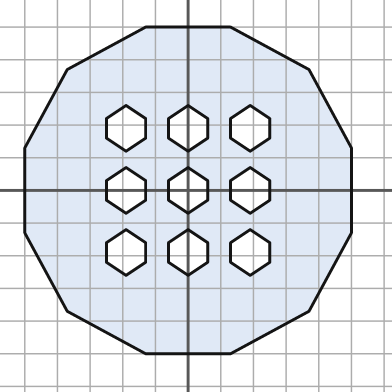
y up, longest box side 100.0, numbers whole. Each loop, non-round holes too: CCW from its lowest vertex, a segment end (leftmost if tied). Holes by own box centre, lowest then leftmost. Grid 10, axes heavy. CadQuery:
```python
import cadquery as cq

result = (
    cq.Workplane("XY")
    .moveTo(-13.0, -50.0)
    .lineTo(13.0, -50.0)
    .lineTo(37.0, -37.0)
    .lineTo(50.0, -13.0)
    .lineTo(50.0, 13.0)
    .lineTo(37.0, 37.0)
    .lineTo(13.0, 50.0)
    .lineTo(-13.0, 50.0)
    .lineTo(-37.0, 37.0)
    .lineTo(-50.0, 13.0)
    .lineTo(-50.0, -13.0)
    .lineTo(-37.0, -37.0)
    .close()
    .moveTo(-19.0, -26.0)
    .lineTo(-13.0, -22.0)
    .lineTo(-13.0, -16.0)
    .lineTo(-19.0, -12.0)
    .lineTo(-25.0, -16.0)
    .lineTo(-25.0, -22.0)
    .close()
    .moveTo(0.0, -26.0)
    .lineTo(6.0, -22.0)
    .lineTo(6.0, -16.0)
    .lineTo(0.0, -12.0)
    .lineTo(-6.0, -16.0)
    .lineTo(-6.0, -22.0)
    .close()
    .moveTo(19.0, -26.0)
    .lineTo(25.0, -22.0)
    .lineTo(25.0, -16.0)
    .lineTo(19.0, -12.0)
    .lineTo(13.0, -16.0)
    .lineTo(13.0, -22.0)
    .close()
    .moveTo(-19.0, -7.0)
    .lineTo(-13.0, -3.0)
    .lineTo(-13.0, 3.0)
    .lineTo(-19.0, 7.0)
    .lineTo(-25.0, 3.0)
    .lineTo(-25.0, -3.0)
    .close()
    .moveTo(0.0, -7.0)
    .lineTo(6.0, -3.0)
    .lineTo(6.0, 3.0)
    .lineTo(0.0, 7.0)
    .lineTo(-6.0, 3.0)
    .lineTo(-6.0, -3.0)
    .close()
    .moveTo(19.0, -7.0)
    .lineTo(25.0, -3.0)
    .lineTo(25.0, 3.0)
    .lineTo(19.0, 7.0)
    .lineTo(13.0, 3.0)
    .lineTo(13.0, -3.0)
    .close()
    .moveTo(-19.0, 12.0)
    .lineTo(-13.0, 16.0)
    .lineTo(-13.0, 22.0)
    .lineTo(-19.0, 26.0)
    .lineTo(-25.0, 22.0)
    .lineTo(-25.0, 16.0)
    .close()
    .moveTo(0.0, 12.0)
    .lineTo(6.0, 16.0)
    .lineTo(6.0, 22.0)
    .lineTo(0.0, 26.0)
    .lineTo(-6.0, 22.0)
    .lineTo(-6.0, 16.0)
    .close()
    .moveTo(19.0, 12.0)
    .lineTo(25.0, 16.0)
    .lineTo(25.0, 22.0)
    .lineTo(19.0, 26.0)
    .lineTo(13.0, 22.0)
    .lineTo(13.0, 16.0)
    .close()
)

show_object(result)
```